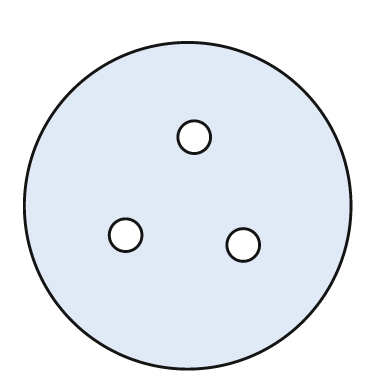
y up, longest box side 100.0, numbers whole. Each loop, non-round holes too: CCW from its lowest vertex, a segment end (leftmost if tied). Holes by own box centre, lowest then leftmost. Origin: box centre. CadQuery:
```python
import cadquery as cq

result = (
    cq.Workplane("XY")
    .moveTo(0.0, 0.0)
    .circle(50.0)
    .moveTo(17.0, -12.0)
    .circle(5.0)
    .moveTo(-19.0, -9.0)
    .circle(5.0)
    .moveTo(2.0, 21.0)
    .circle(5.0)
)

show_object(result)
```